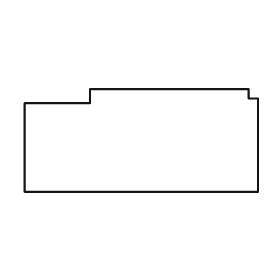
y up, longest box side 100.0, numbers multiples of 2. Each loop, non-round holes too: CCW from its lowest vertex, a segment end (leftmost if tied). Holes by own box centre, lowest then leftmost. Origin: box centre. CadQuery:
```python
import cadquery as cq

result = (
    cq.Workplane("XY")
    .moveTo(-50.0, -22.0)
    .lineTo(50.0, -22.0)
    .lineTo(50.0, 18.0)
    .lineTo(46.0, 18.0)
    .lineTo(46.0, 22.0)
    .lineTo(-22.0, 22.0)
    .lineTo(-22.0, 16.0)
    .lineTo(-50.0, 16.0)
    .close()
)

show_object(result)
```